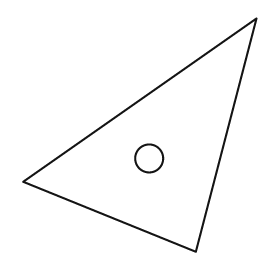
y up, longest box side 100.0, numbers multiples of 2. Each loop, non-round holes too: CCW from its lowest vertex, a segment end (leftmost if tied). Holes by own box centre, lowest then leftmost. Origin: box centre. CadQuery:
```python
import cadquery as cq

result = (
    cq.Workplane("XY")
    .moveTo(24.0, -50.0)
    .lineTo(50.0, 50.0)
    .lineTo(-50.0, -20.0)
    .close()
    .moveTo(4.0, -10.0)
    .circle(6.0)
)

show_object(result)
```